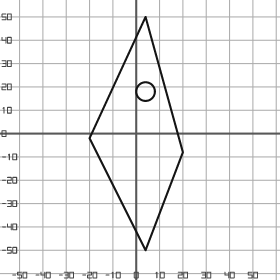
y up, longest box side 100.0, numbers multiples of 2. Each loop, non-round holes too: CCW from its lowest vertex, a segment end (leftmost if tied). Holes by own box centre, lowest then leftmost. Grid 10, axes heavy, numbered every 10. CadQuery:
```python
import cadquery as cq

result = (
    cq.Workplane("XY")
    .moveTo(4.0, -50.0)
    .lineTo(20.0, -8.0)
    .lineTo(4.0, 50.0)
    .lineTo(-20.0, -2.0)
    .close()
    .moveTo(4.0, 18.0)
    .circle(4.0)
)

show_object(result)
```